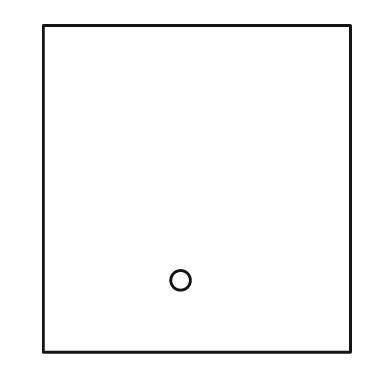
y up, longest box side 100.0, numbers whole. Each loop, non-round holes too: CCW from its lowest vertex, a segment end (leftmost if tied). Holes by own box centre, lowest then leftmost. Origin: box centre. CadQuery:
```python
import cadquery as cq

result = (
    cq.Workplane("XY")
    .moveTo(-47.0, -50.0)
    .lineTo(47.0, -50.0)
    .lineTo(47.0, 50.0)
    .lineTo(-47.0, 50.0)
    .close()
    .moveTo(-5.0, -28.0)
    .circle(3.0)
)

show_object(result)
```